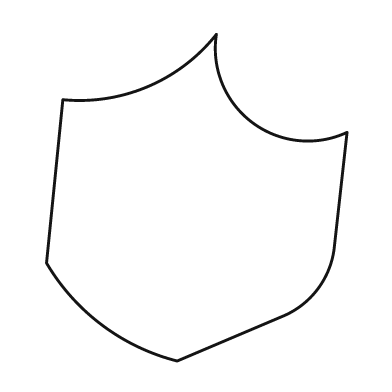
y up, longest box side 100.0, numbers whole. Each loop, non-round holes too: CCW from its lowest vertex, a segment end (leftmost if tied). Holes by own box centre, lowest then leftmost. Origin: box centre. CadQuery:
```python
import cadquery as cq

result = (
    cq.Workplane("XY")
    .moveTo(-6.0, -50.0)
    .lineTo(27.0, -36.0)
    .threePointArc((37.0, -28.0), (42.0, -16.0))
    .lineTo(46.0, 20.0)
    .threePointArc((17.0, 23.0), (6.0, 50.0))
    .threePointArc((-15.0, 34.0), (-41.0, 30.0))
    .lineTo(-46.0, -20.0)
    .threePointArc((-29.0, -39.0), (-6.0, -50.0))
    .close()
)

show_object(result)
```